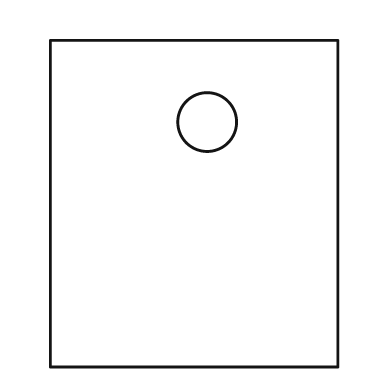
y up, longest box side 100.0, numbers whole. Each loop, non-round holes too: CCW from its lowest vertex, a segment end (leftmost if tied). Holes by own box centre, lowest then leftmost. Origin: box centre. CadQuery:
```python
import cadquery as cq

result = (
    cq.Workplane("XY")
    .moveTo(-44.0, -50.0)
    .lineTo(44.0, -50.0)
    .lineTo(44.0, 50.0)
    .lineTo(-44.0, 50.0)
    .close()
    .moveTo(4.0, 25.0)
    .circle(9.0)
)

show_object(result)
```